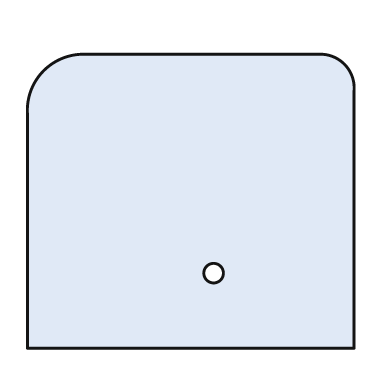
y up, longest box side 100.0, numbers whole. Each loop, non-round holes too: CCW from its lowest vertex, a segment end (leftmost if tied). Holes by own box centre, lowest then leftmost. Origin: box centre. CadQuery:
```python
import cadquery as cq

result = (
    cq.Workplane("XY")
    .moveTo(-50.0, -45.0)
    .lineTo(50.0, -45.0)
    .lineTo(50.0, 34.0)
    .threePointArc((47.0, 42.0), (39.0, 45.0))
    .lineTo(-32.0, 45.0)
    .threePointArc((-45.0, 40.0), (-50.0, 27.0))
    .close()
    .moveTo(7.0, -22.0)
    .circle(3.0)
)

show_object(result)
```